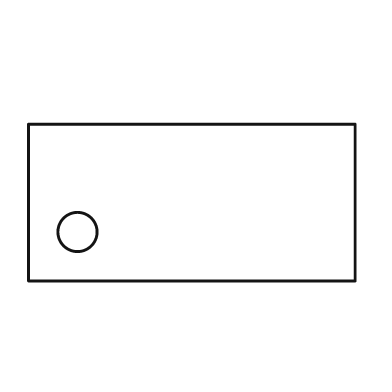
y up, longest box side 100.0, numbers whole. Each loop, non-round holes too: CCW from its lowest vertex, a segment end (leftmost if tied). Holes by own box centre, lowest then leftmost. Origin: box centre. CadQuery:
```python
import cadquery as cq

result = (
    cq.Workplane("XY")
    .moveTo(-50.0, -24.0)
    .lineTo(50.0, -24.0)
    .lineTo(50.0, 24.0)
    .lineTo(-50.0, 24.0)
    .close()
    .moveTo(-35.0, -9.0)
    .circle(6.0)
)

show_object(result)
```